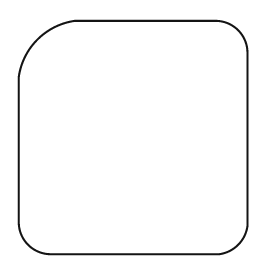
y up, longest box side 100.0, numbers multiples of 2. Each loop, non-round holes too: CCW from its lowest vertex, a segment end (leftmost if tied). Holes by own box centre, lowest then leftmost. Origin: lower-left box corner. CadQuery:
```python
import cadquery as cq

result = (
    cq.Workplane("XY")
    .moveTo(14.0, 0.0)
    .lineTo(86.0, 0.0)
    .threePointArc((94.0, 4.0), (98.0, 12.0))
    .lineTo(98.0, 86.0)
    .threePointArc((94.0, 96.0), (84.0, 100.0))
    .lineTo(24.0, 100.0)
    .threePointArc((8.0, 92.0), (0.0, 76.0))
    .lineTo(0.0, 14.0)
    .threePointArc((4.0, 4.0), (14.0, 0.0))
    .close()
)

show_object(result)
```